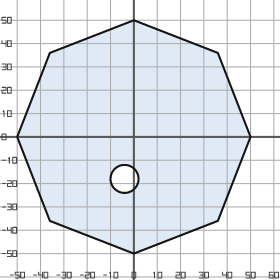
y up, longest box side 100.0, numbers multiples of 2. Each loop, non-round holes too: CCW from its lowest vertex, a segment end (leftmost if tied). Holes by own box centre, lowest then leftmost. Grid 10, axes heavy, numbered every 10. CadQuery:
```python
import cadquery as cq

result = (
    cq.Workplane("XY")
    .moveTo(0.0, -50.0)
    .lineTo(36.0, -36.0)
    .lineTo(50.0, 0.0)
    .lineTo(36.0, 36.0)
    .lineTo(0.0, 50.0)
    .lineTo(-36.0, 36.0)
    .lineTo(-50.0, 0.0)
    .lineTo(-36.0, -36.0)
    .close()
    .moveTo(-4.0, -18.0)
    .circle(6.0)
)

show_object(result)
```